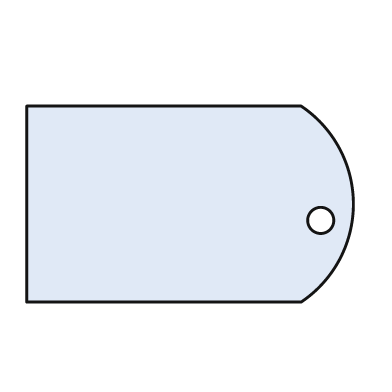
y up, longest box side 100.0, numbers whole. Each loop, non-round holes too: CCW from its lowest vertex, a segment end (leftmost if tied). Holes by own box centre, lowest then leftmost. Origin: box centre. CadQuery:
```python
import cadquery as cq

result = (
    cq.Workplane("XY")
    .moveTo(-50.0, -30.0)
    .lineTo(34.0, -30.0)
    .threePointArc((50.0, 0.0), (34.0, 30.0))
    .lineTo(-50.0, 30.0)
    .close()
    .moveTo(40.0, -5.0)
    .circle(4.0)
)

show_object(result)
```